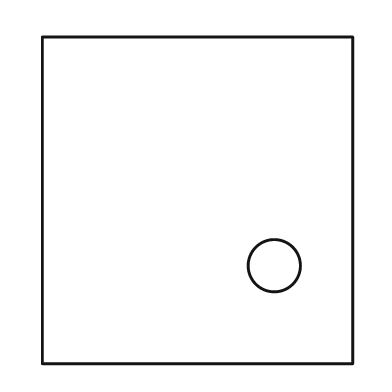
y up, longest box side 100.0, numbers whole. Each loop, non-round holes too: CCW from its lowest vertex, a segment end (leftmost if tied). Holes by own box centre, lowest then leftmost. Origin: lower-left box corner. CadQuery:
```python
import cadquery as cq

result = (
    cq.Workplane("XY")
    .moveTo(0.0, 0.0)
    .lineTo(95.0, 0.0)
    .lineTo(95.0, 100.0)
    .lineTo(0.0, 100.0)
    .close()
    .moveTo(71.0, 30.0)
    .circle(8.0)
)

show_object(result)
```